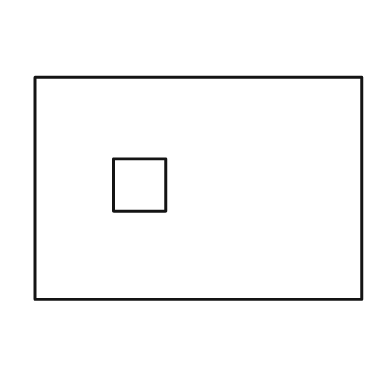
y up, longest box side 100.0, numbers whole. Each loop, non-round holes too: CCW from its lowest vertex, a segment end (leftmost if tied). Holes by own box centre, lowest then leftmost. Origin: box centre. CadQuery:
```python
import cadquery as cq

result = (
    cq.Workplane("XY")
    .moveTo(-50.0, -34.0)
    .lineTo(50.0, -34.0)
    .lineTo(50.0, 34.0)
    .lineTo(-50.0, 34.0)
    .close()
    .moveTo(-26.0, -7.0)
    .lineTo(-10.0, -7.0)
    .lineTo(-10.0, 9.0)
    .lineTo(-26.0, 9.0)
    .close()
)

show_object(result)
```